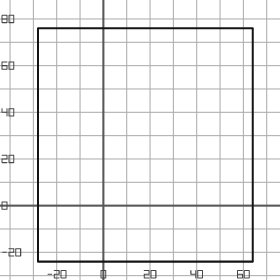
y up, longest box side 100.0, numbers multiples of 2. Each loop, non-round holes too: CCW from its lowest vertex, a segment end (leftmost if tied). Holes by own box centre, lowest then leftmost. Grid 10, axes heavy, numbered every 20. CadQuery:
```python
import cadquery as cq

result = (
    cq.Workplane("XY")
    .moveTo(-28.0, -24.0)
    .lineTo(64.0, -24.0)
    .lineTo(64.0, 76.0)
    .lineTo(-28.0, 76.0)
    .close()
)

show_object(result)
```